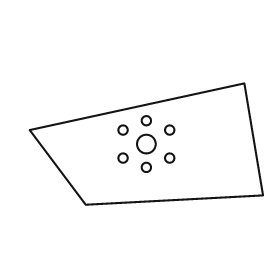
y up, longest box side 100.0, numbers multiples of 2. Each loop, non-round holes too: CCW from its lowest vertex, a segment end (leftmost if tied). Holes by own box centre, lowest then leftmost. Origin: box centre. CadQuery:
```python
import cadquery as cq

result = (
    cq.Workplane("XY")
    .moveTo(-26.0, -26.0)
    .lineTo(50.0, -22.0)
    .lineTo(42.0, 26.0)
    .lineTo(-50.0, 6.0)
    .close()
    .moveTo(0.0, -10.0)
    .circle(2.0)
    .moveTo(-10.0, -6.0)
    .circle(2.0)
    .moveTo(10.0, -6.0)
    .circle(2.0)
    .moveTo(0.0, 0.0)
    .circle(4.0)
    .moveTo(-10.0, 6.0)
    .circle(2.0)
    .moveTo(10.0, 6.0)
    .circle(2.0)
    .moveTo(0.0, 10.0)
    .circle(2.0)
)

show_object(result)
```